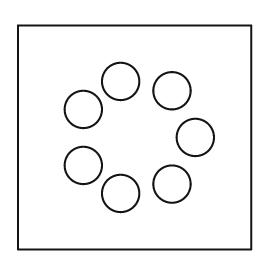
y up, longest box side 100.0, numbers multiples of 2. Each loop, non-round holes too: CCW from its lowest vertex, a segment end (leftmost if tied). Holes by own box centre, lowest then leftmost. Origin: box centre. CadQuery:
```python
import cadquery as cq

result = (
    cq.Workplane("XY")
    .moveTo(-50.0, -48.0)
    .lineTo(50.0, -48.0)
    .lineTo(50.0, 48.0)
    .lineTo(-50.0, 48.0)
    .close()
    .moveTo(-6.0, -24.0)
    .circle(8.0)
    .moveTo(16.0, -20.0)
    .circle(8.0)
    .moveTo(-22.0, -12.0)
    .circle(8.0)
    .moveTo(26.0, 0.0)
    .circle(8.0)
    .moveTo(-22.0, 12.0)
    .circle(8.0)
    .moveTo(16.0, 20.0)
    .circle(8.0)
    .moveTo(-6.0, 24.0)
    .circle(8.0)
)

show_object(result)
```